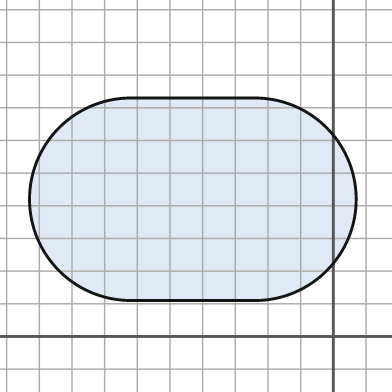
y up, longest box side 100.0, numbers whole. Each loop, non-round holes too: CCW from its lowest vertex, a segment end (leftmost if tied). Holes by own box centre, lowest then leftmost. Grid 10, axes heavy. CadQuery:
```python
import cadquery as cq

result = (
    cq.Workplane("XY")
    .moveTo(-62.0, 11.0)
    .lineTo(-24.0, 11.0)
    .threePointArc((7.0, 42.0), (-24.0, 73.0))
    .lineTo(-62.0, 73.0)
    .threePointArc((-93.0, 42.0), (-62.0, 11.0))
    .close()
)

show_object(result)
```